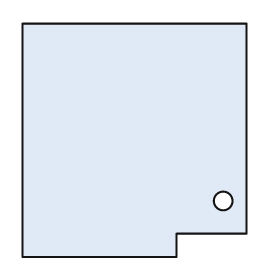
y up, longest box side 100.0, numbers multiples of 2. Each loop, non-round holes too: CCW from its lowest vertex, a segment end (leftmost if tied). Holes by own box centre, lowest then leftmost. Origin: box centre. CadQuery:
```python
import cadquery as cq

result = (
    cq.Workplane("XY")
    .moveTo(-48.0, -50.0)
    .lineTo(18.0, -50.0)
    .lineTo(18.0, -40.0)
    .lineTo(48.0, -40.0)
    .lineTo(48.0, 50.0)
    .lineTo(-48.0, 50.0)
    .close()
    .moveTo(38.0, -26.0)
    .circle(4.0)
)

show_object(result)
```